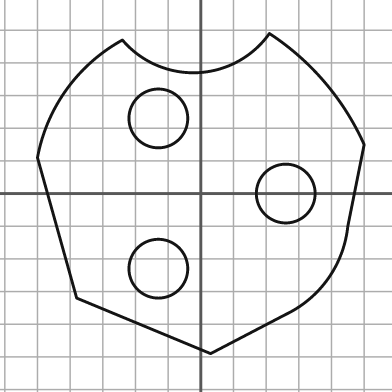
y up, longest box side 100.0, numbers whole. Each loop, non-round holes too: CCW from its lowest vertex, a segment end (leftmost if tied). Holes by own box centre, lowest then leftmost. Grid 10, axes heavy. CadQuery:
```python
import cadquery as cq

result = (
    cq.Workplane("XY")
    .moveTo(3.0, -49.0)
    .lineTo(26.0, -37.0)
    .threePointArc((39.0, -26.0), (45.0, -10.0))
    .lineTo(50.0, 15.0)
    .threePointArc((38.0, 34.0), (21.0, 49.0))
    .threePointArc((-1.0, 37.0), (-24.0, 47.0))
    .threePointArc((-41.0, 32.0), (-50.0, 11.0))
    .lineTo(-38.0, -32.0)
    .close()
    .moveTo(-13.0, -23.0)
    .circle(9.0)
    .moveTo(26.0, 0.0)
    .circle(9.0)
    .moveTo(-13.0, 23.0)
    .circle(9.0)
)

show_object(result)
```